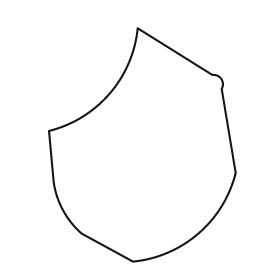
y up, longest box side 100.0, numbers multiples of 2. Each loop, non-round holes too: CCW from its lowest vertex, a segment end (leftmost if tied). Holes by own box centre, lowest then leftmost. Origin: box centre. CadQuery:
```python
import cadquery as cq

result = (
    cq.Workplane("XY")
    .moveTo(-4.0, -50.0)
    .threePointArc((24.0, -38.0), (40.0, -12.0))
    .lineTo(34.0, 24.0)
    .threePointArc((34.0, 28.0), (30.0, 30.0))
    .lineTo(-2.0, 50.0)
    .threePointArc((-14.0, 22.0), (-40.0, 6.0))
    .lineTo(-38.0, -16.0)
    .threePointArc((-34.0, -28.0), (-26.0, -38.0))
    .close()
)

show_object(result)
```